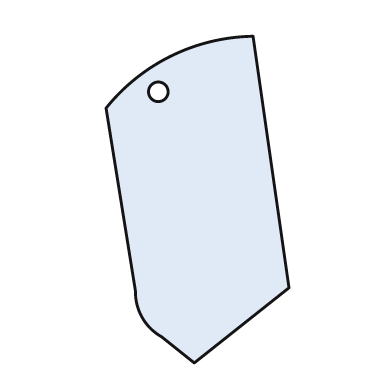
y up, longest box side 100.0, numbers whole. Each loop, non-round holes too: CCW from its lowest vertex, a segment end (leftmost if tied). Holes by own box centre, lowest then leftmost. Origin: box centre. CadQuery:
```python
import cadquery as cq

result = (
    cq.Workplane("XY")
    .moveTo(-1.0, -50.0)
    .lineTo(28.0, -27.0)
    .lineTo(17.0, 50.0)
    .threePointArc((-8.0, 44.0), (-28.0, 28.0))
    .lineTo(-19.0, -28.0)
    .threePointArc((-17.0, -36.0), (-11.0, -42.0))
    .close()
    .moveTo(-12.0, 33.0)
    .circle(3.0)
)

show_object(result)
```